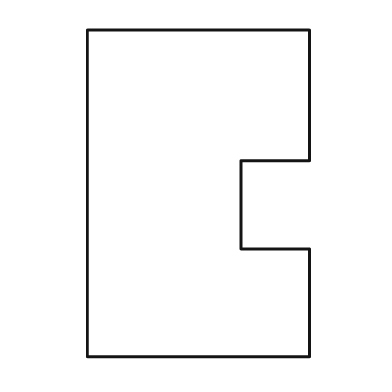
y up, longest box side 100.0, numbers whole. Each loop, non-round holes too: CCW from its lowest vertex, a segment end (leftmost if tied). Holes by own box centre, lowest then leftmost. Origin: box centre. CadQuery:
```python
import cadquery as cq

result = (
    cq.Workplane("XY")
    .moveTo(-34.0, -50.0)
    .lineTo(34.0, -50.0)
    .lineTo(34.0, -17.0)
    .lineTo(13.0, -17.0)
    .lineTo(13.0, 10.0)
    .lineTo(34.0, 10.0)
    .lineTo(34.0, 50.0)
    .lineTo(-34.0, 50.0)
    .close()
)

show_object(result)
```